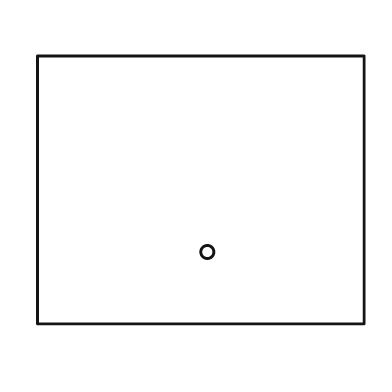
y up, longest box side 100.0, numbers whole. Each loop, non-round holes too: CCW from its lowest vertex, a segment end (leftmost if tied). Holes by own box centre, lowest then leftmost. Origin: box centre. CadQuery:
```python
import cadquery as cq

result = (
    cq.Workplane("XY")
    .moveTo(-50.0, -41.0)
    .lineTo(50.0, -41.0)
    .lineTo(50.0, 41.0)
    .lineTo(-50.0, 41.0)
    .close()
    .moveTo(2.0, -19.0)
    .circle(2.0)
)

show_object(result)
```